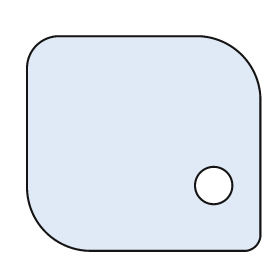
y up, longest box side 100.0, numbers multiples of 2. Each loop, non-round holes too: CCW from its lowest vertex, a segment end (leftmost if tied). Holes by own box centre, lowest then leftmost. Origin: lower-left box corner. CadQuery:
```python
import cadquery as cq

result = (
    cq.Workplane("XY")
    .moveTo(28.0, 0.0)
    .lineTo(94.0, 0.0)
    .threePointArc((98.0, 2.0), (100.0, 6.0))
    .lineTo(100.0, 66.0)
    .threePointArc((92.0, 84.0), (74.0, 92.0))
    .lineTo(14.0, 92.0)
    .threePointArc((4.0, 88.0), (0.0, 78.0))
    .lineTo(0.0, 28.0)
    .threePointArc((8.0, 8.0), (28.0, 0.0))
    .close()
    .moveTo(80.0, 28.0)
    .circle(8.0)
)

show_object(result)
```